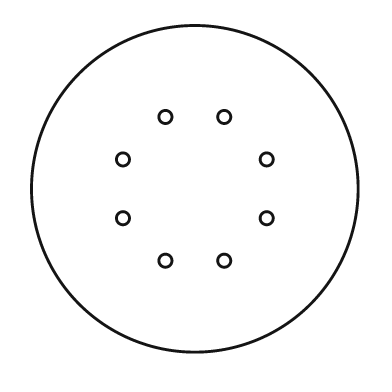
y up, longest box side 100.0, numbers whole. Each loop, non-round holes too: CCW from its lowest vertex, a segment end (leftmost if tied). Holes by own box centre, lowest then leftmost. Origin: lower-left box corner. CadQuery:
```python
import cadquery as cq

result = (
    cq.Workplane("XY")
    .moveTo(50.0, 50.0)
    .circle(50.0)
    .moveTo(41.0, 28.0)
    .circle(2.0)
    .moveTo(59.0, 28.0)
    .circle(2.0)
    .moveTo(28.0, 41.0)
    .circle(2.0)
    .moveTo(72.0, 41.0)
    .circle(2.0)
    .moveTo(28.0, 59.0)
    .circle(2.0)
    .moveTo(72.0, 59.0)
    .circle(2.0)
    .moveTo(41.0, 72.0)
    .circle(2.0)
    .moveTo(59.0, 72.0)
    .circle(2.0)
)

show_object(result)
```